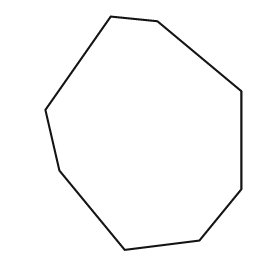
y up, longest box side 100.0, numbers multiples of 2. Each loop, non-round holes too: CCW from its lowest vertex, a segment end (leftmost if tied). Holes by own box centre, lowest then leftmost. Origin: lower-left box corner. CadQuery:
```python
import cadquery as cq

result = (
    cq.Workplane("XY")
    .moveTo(34.0, 0.0)
    .lineTo(66.0, 4.0)
    .lineTo(84.0, 26.0)
    .lineTo(84.0, 68.0)
    .lineTo(48.0, 98.0)
    .lineTo(28.0, 100.0)
    .lineTo(0.0, 60.0)
    .lineTo(6.0, 34.0)
    .close()
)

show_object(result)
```